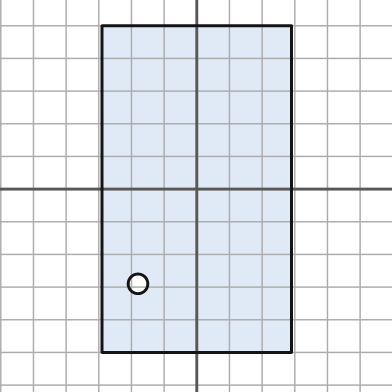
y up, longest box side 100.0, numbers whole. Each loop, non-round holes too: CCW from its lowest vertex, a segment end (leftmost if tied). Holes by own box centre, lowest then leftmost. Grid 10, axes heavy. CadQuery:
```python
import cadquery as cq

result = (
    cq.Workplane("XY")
    .moveTo(-29.0, -50.0)
    .lineTo(29.0, -50.0)
    .lineTo(29.0, 50.0)
    .lineTo(-29.0, 50.0)
    .close()
    .moveTo(-18.0, -29.0)
    .circle(3.0)
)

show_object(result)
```